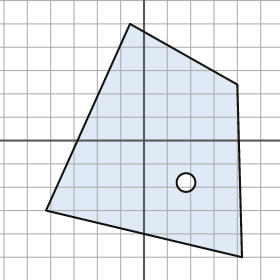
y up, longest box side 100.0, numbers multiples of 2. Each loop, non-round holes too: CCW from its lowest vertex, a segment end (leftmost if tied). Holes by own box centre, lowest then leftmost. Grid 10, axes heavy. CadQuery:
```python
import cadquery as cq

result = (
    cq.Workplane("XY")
    .moveTo(42.0, -50.0)
    .lineTo(40.0, 24.0)
    .lineTo(-6.0, 50.0)
    .lineTo(-42.0, -30.0)
    .close()
    .moveTo(18.0, -18.0)
    .circle(4.0)
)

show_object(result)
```